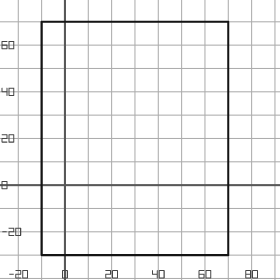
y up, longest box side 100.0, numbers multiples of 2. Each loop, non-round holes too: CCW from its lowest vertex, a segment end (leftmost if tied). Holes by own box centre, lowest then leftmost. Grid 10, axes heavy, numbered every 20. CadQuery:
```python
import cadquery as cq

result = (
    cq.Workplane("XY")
    .moveTo(-10.0, -30.0)
    .lineTo(70.0, -30.0)
    .lineTo(70.0, 70.0)
    .lineTo(-10.0, 70.0)
    .close()
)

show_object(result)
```